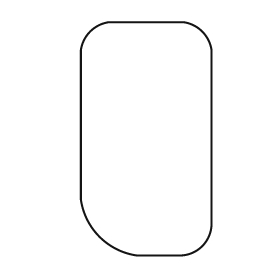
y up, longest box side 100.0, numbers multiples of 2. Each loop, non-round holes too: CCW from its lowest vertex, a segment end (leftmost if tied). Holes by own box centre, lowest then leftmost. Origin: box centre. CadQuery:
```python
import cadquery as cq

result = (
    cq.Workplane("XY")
    .moveTo(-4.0, -50.0)
    .lineTo(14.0, -50.0)
    .threePointArc((24.0, -46.0), (28.0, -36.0))
    .lineTo(28.0, 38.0)
    .threePointArc((24.0, 46.0), (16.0, 50.0))
    .lineTo(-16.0, 50.0)
    .threePointArc((-24.0, 46.0), (-28.0, 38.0))
    .lineTo(-28.0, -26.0)
    .threePointArc((-20.0, -42.0), (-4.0, -50.0))
    .close()
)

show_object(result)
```